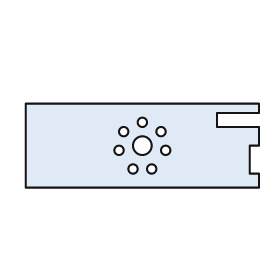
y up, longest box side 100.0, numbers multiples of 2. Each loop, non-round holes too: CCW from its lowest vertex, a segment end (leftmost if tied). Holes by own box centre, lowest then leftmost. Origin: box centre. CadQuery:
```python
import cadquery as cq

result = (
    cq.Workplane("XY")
    .moveTo(-50.0, -18.0)
    .lineTo(50.0, -18.0)
    .lineTo(50.0, -12.0)
    .lineTo(46.0, -12.0)
    .lineTo(46.0, 0.0)
    .lineTo(50.0, 0.0)
    .lineTo(50.0, 8.0)
    .lineTo(32.0, 8.0)
    .lineTo(32.0, 14.0)
    .lineTo(50.0, 14.0)
    .lineTo(50.0, 18.0)
    .lineTo(-50.0, 18.0)
    .close()
    .moveTo(-4.0, -10.0)
    .circle(2.0)
    .moveTo(4.0, -10.0)
    .circle(2.0)
    .moveTo(-10.0, -2.0)
    .circle(2.0)
    .moveTo(10.0, -2.0)
    .circle(2.0)
    .moveTo(0.0, 0.0)
    .circle(4.0)
    .moveTo(-8.0, 6.0)
    .circle(2.0)
    .moveTo(8.0, 6.0)
    .circle(2.0)
    .moveTo(0.0, 10.0)
    .circle(2.0)
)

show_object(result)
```